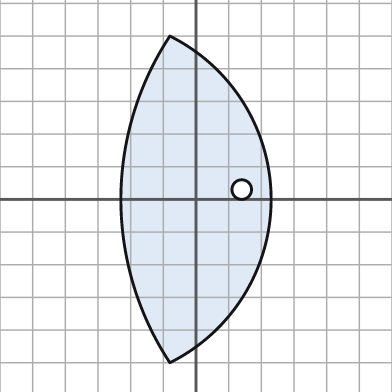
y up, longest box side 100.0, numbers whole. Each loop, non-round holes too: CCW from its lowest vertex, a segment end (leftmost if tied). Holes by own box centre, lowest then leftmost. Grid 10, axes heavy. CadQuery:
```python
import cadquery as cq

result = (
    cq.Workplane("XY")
    .moveTo(-8.0, -50.0)
    .threePointArc((23.0, 0.0), (-8.0, 50.0))
    .threePointArc((-23.0, 0.0), (-8.0, -50.0))
    .close()
    .moveTo(14.0, 3.0)
    .circle(3.0)
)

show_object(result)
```